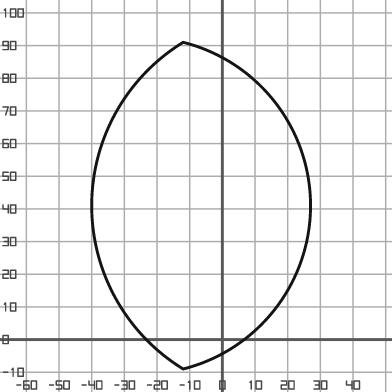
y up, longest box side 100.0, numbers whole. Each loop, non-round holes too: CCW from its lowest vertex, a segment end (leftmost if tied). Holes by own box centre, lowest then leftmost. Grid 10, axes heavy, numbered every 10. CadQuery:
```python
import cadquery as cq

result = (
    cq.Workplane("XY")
    .moveTo(-12.0, -9.0)
    .threePointArc((27.0, 41.0), (-12.0, 91.0))
    .threePointArc((-40.0, 41.0), (-12.0, -9.0))
    .close()
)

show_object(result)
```